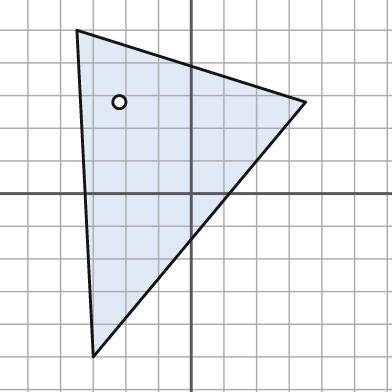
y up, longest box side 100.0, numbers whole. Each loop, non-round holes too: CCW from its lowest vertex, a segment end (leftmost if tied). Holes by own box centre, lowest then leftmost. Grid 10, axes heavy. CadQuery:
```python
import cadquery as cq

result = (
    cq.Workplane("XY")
    .moveTo(-30.0, -50.0)
    .lineTo(35.0, 28.0)
    .lineTo(-35.0, 50.0)
    .close()
    .moveTo(-22.0, 28.0)
    .circle(2.0)
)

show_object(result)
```